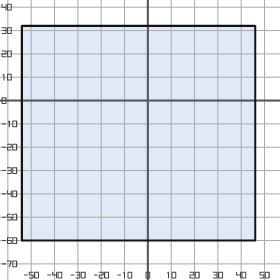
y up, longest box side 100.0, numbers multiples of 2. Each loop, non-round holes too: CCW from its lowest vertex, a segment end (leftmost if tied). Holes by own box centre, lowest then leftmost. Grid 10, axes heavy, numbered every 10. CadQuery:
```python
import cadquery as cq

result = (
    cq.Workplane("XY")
    .moveTo(-54.0, -60.0)
    .lineTo(46.0, -60.0)
    .lineTo(46.0, 32.0)
    .lineTo(-54.0, 32.0)
    .close()
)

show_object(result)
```